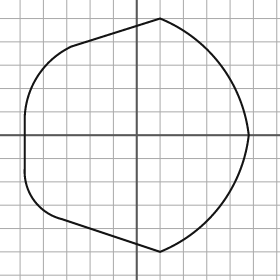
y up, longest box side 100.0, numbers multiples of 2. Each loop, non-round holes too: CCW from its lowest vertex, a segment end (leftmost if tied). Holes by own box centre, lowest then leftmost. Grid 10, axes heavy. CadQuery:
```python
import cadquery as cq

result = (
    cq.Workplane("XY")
    .moveTo(10.0, -50.0)
    .threePointArc((36.0, -30.0), (48.0, 0.0))
    .threePointArc((36.0, 30.0), (10.0, 50.0))
    .lineTo(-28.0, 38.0)
    .threePointArc((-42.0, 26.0), (-48.0, 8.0))
    .lineTo(-48.0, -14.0)
    .threePointArc((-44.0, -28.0), (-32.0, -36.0))
    .close()
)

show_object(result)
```